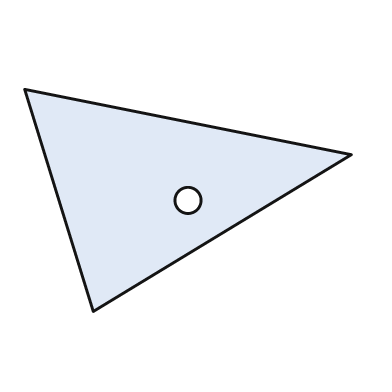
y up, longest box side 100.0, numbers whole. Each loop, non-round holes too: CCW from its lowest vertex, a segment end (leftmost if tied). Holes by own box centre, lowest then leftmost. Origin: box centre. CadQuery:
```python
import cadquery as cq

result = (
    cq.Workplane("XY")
    .moveTo(-29.0, -34.0)
    .lineTo(50.0, 14.0)
    .lineTo(-50.0, 34.0)
    .close()
    .moveTo(0.0, 0.0)
    .circle(4.0)
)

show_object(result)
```